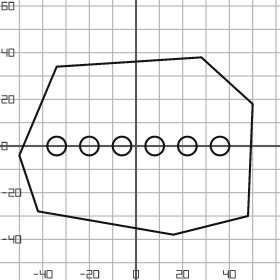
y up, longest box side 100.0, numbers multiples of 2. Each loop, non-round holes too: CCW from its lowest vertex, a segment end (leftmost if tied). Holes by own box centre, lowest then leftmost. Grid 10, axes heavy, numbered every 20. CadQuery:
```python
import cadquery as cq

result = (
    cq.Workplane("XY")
    .moveTo(16.0, -38.0)
    .lineTo(48.0, -30.0)
    .lineTo(50.0, 18.0)
    .lineTo(28.0, 38.0)
    .lineTo(-34.0, 34.0)
    .lineTo(-50.0, -4.0)
    .lineTo(-42.0, -28.0)
    .close()
    .moveTo(-34.0, 0.0)
    .circle(4.0)
    .moveTo(-20.0, 0.0)
    .circle(4.0)
    .moveTo(-6.0, 0.0)
    .circle(4.0)
    .moveTo(8.0, 0.0)
    .circle(4.0)
    .moveTo(22.0, 0.0)
    .circle(4.0)
    .moveTo(36.0, 0.0)
    .circle(4.0)
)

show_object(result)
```